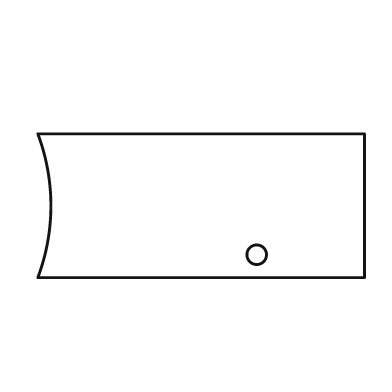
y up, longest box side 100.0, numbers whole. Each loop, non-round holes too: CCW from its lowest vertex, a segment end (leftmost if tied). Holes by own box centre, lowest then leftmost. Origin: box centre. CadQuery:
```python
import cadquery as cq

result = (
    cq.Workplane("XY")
    .moveTo(-50.0, -22.0)
    .lineTo(50.0, -22.0)
    .lineTo(50.0, 22.0)
    .lineTo(-50.0, 22.0)
    .threePointArc((-46.0, 0.0), (-50.0, -22.0))
    .close()
    .moveTo(17.0, -15.0)
    .circle(3.0)
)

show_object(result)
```